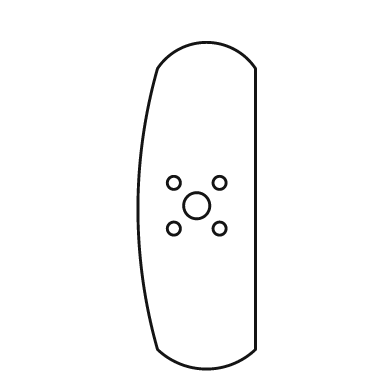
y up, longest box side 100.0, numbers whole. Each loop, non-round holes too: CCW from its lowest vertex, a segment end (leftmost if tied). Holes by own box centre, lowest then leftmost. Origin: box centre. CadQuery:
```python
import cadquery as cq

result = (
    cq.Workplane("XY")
    .moveTo(-12.0, -44.0)
    .threePointArc((3.0, -50.0), (18.0, -44.0))
    .lineTo(18.0, 42.0)
    .threePointArc((3.0, 50.0), (-12.0, 42.0))
    .threePointArc((-18.0, -1.0), (-12.0, -44.0))
    .close()
    .moveTo(-7.0, -7.0)
    .circle(2.0)
    .moveTo(7.0, -7.0)
    .circle(2.0)
    .moveTo(0.0, 0.0)
    .circle(4.0)
    .moveTo(-7.0, 7.0)
    .circle(2.0)
    .moveTo(7.0, 7.0)
    .circle(2.0)
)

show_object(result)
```